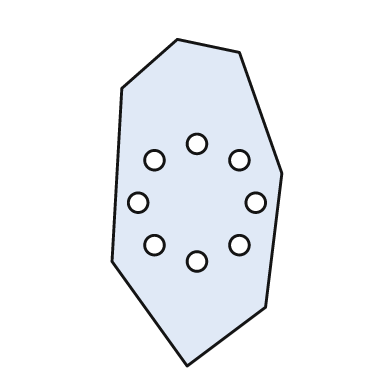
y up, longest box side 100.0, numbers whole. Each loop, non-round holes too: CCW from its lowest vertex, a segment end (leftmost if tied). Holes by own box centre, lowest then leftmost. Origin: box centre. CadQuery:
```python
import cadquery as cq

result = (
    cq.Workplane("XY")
    .moveTo(-3.0, -50.0)
    .lineTo(21.0, -32.0)
    .lineTo(26.0, 9.0)
    .lineTo(13.0, 46.0)
    .lineTo(-6.0, 50.0)
    .lineTo(-23.0, 35.0)
    .lineTo(-26.0, -18.0)
    .close()
    .moveTo(0.0, -18.0)
    .circle(3.0)
    .moveTo(-13.0, -13.0)
    .circle(3.0)
    .moveTo(13.0, -13.0)
    .circle(3.0)
    .moveTo(-18.0, 0.0)
    .circle(3.0)
    .moveTo(18.0, 0.0)
    .circle(3.0)
    .moveTo(-13.0, 13.0)
    .circle(3.0)
    .moveTo(13.0, 13.0)
    .circle(3.0)
    .moveTo(0.0, 18.0)
    .circle(3.0)
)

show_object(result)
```